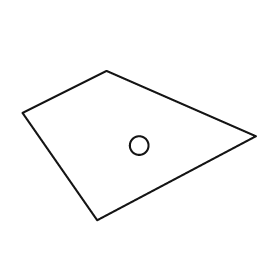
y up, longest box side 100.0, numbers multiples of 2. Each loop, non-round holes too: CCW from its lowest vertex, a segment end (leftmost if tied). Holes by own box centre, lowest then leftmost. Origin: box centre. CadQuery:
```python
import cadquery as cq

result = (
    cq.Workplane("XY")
    .moveTo(-18.0, -32.0)
    .lineTo(50.0, 4.0)
    .lineTo(-14.0, 32.0)
    .lineTo(-50.0, 14.0)
    .close()
    .moveTo(0.0, 0.0)
    .circle(4.0)
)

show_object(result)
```